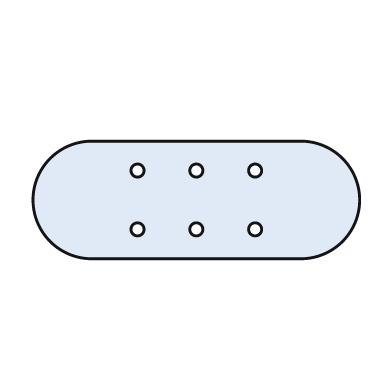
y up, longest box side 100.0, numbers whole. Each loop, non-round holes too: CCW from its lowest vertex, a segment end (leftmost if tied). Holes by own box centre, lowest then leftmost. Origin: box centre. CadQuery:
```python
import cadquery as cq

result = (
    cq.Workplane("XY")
    .moveTo(-32.0, -18.0)
    .lineTo(32.0, -18.0)
    .threePointArc((50.0, 0.0), (32.0, 18.0))
    .lineTo(-32.0, 18.0)
    .threePointArc((-50.0, 0.0), (-32.0, -18.0))
    .close()
    .moveTo(-18.0, -9.0)
    .circle(2.0)
    .moveTo(0.0, -9.0)
    .circle(2.0)
    .moveTo(18.0, -9.0)
    .circle(2.0)
    .moveTo(-18.0, 9.0)
    .circle(2.0)
    .moveTo(0.0, 9.0)
    .circle(2.0)
    .moveTo(18.0, 9.0)
    .circle(2.0)
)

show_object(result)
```